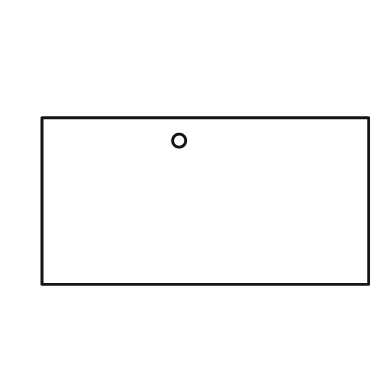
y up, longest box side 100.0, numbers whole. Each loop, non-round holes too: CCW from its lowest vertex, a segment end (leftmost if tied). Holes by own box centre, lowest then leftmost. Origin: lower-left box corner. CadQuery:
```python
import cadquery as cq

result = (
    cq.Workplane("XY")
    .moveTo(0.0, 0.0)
    .lineTo(100.0, 0.0)
    .lineTo(100.0, 51.0)
    .lineTo(0.0, 51.0)
    .close()
    .moveTo(42.0, 44.0)
    .circle(2.0)
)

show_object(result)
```